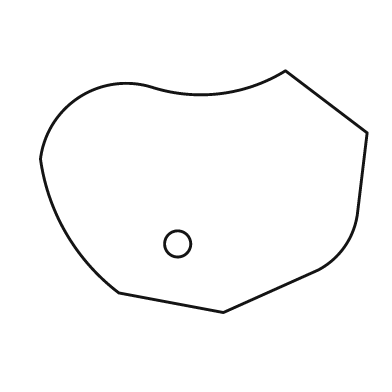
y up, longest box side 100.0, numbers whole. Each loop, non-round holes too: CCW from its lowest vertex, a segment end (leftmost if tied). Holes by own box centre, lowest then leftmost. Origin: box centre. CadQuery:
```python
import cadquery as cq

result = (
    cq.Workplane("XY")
    .moveTo(6.0, -37.0)
    .lineTo(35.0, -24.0)
    .threePointArc((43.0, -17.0), (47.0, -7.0))
    .lineTo(50.0, 18.0)
    .lineTo(25.0, 37.0)
    .threePointArc((5.0, 30.0), (-16.0, 32.0))
    .threePointArc((-38.0, 29.0), (-50.0, 10.0))
    .threePointArc((-42.0, -13.0), (-26.0, -31.0))
    .close()
    .moveTo(-8.0, -16.0)
    .circle(4.0)
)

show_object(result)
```